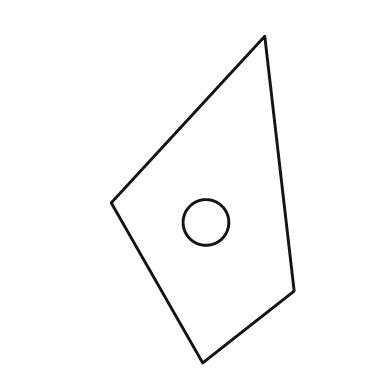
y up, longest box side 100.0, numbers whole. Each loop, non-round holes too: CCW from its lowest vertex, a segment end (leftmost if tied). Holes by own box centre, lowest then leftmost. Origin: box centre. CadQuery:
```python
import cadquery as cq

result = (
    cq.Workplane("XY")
    .moveTo(0.0, -50.0)
    .lineTo(28.0, -28.0)
    .lineTo(19.0, 50.0)
    .lineTo(-28.0, -1.0)
    .close()
    .moveTo(1.0, -7.0)
    .circle(7.0)
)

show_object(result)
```